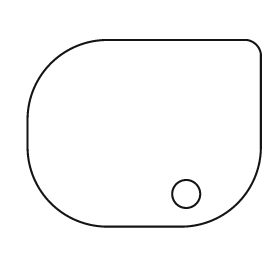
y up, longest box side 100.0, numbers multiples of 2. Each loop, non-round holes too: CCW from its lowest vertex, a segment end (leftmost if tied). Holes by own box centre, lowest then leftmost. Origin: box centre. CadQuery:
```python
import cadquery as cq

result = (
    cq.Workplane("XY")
    .moveTo(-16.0, -40.0)
    .lineTo(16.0, -40.0)
    .threePointArc((40.0, -30.0), (50.0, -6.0))
    .lineTo(50.0, 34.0)
    .threePointArc((48.0, 38.0), (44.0, 40.0))
    .lineTo(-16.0, 40.0)
    .threePointArc((-40.0, 30.0), (-50.0, 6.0))
    .lineTo(-50.0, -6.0)
    .threePointArc((-40.0, -30.0), (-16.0, -40.0))
    .close()
    .moveTo(18.0, -26.0)
    .circle(6.0)
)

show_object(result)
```